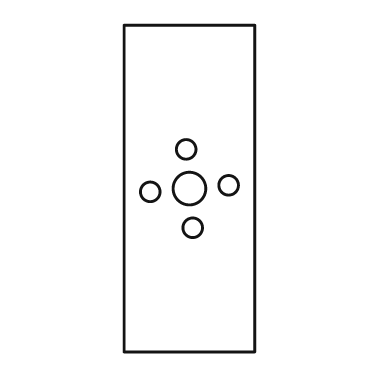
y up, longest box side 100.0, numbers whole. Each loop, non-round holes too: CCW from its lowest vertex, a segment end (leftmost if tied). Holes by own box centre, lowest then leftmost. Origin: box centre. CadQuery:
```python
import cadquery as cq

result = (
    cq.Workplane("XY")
    .moveTo(-20.0, -50.0)
    .lineTo(20.0, -50.0)
    .lineTo(20.0, 50.0)
    .lineTo(-20.0, 50.0)
    .close()
    .moveTo(1.0, -12.0)
    .circle(3.0)
    .moveTo(-12.0, -1.0)
    .circle(3.0)
    .moveTo(0.0, 0.0)
    .circle(5.0)
    .moveTo(12.0, 1.0)
    .circle(3.0)
    .moveTo(-1.0, 12.0)
    .circle(3.0)
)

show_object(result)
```